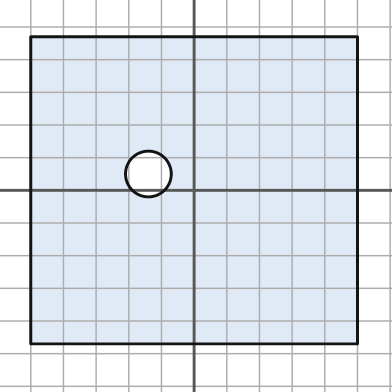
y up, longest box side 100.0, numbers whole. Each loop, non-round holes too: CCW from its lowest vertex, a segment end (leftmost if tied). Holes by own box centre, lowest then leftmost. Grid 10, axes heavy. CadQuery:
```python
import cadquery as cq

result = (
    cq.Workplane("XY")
    .moveTo(-50.0, -47.0)
    .lineTo(50.0, -47.0)
    .lineTo(50.0, 47.0)
    .lineTo(-50.0, 47.0)
    .close()
    .moveTo(-14.0, 5.0)
    .circle(7.0)
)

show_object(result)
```